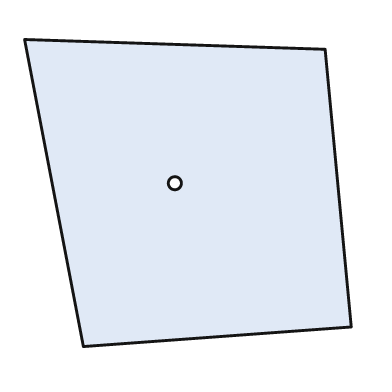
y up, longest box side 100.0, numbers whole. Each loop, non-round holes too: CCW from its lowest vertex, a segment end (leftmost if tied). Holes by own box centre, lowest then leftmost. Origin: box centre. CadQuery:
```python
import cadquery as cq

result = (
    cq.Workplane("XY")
    .moveTo(-32.0, -47.0)
    .lineTo(50.0, -41.0)
    .lineTo(42.0, 44.0)
    .lineTo(-50.0, 47.0)
    .close()
    .moveTo(-4.0, 3.0)
    .circle(2.0)
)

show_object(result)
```